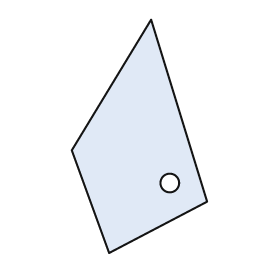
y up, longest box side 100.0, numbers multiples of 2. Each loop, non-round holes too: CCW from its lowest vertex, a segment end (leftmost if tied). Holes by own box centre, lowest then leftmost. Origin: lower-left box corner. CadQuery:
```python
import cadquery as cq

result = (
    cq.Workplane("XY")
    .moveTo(16.0, 0.0)
    .lineTo(58.0, 22.0)
    .lineTo(34.0, 100.0)
    .lineTo(0.0, 44.0)
    .close()
    .moveTo(42.0, 30.0)
    .circle(4.0)
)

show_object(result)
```